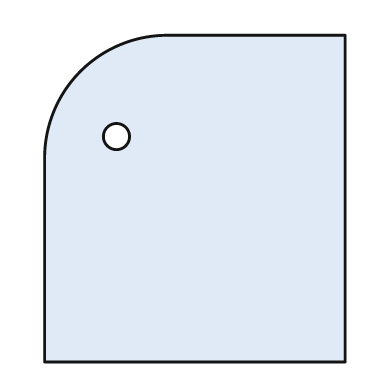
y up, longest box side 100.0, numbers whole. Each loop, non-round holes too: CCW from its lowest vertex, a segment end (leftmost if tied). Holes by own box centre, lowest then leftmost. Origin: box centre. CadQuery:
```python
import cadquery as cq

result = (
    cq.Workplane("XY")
    .moveTo(-46.0, -50.0)
    .lineTo(46.0, -50.0)
    .lineTo(46.0, 50.0)
    .lineTo(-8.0, 50.0)
    .threePointArc((-35.0, 39.0), (-46.0, 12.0))
    .close()
    .moveTo(-24.0, 19.0)
    .circle(4.0)
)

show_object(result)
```